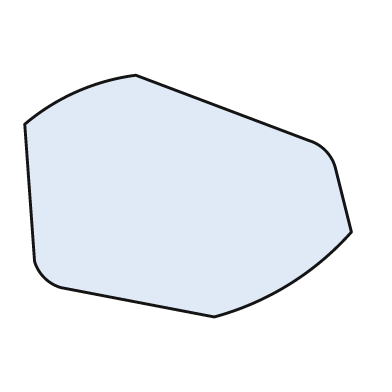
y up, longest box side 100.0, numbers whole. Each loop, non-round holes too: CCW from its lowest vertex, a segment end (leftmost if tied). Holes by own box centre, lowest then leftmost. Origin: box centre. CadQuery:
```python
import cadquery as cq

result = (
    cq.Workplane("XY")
    .moveTo(8.0, -37.0)
    .threePointArc((31.0, -27.0), (50.0, -11.0))
    .lineTo(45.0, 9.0)
    .threePointArc((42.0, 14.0), (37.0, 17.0))
    .lineTo(-16.0, 37.0)
    .threePointArc((-34.0, 32.0), (-50.0, 22.0))
    .lineTo(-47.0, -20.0)
    .threePointArc((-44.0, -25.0), (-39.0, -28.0))
    .close()
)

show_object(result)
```